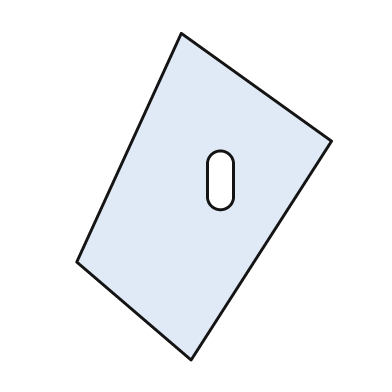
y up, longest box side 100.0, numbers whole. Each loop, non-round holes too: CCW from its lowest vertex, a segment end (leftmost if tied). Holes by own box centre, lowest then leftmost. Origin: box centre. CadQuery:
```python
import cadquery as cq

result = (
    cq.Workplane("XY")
    .moveTo(-4.0, -50.0)
    .lineTo(39.0, 17.0)
    .lineTo(-7.0, 50.0)
    .lineTo(-39.0, -20.0)
    .close()
    .moveTo(1.0, 0.0)
    .threePointArc((5.0, -4.0), (9.0, 0.0))
    .lineTo(9.0, 10.0)
    .threePointArc((5.0, 14.0), (1.0, 10.0))
    .close()
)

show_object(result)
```